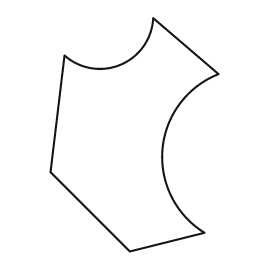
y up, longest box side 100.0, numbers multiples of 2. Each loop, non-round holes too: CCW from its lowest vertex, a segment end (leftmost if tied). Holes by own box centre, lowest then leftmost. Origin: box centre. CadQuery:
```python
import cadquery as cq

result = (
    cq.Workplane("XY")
    .moveTo(-2.0, -50.0)
    .lineTo(30.0, -42.0)
    .threePointArc((12.0, -6.0), (36.0, 26.0))
    .lineTo(8.0, 50.0)
    .threePointArc((-6.0, 30.0), (-30.0, 34.0))
    .lineTo(-36.0, -16.0)
    .close()
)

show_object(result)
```